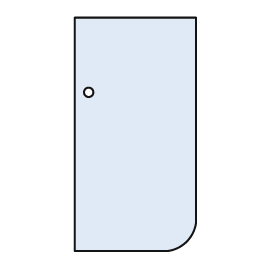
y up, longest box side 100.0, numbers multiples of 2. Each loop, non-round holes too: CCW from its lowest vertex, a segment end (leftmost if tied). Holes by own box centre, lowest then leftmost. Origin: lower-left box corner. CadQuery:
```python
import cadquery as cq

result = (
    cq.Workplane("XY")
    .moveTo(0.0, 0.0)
    .lineTo(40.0, 0.0)
    .threePointArc((48.0, 4.0), (52.0, 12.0))
    .lineTo(52.0, 100.0)
    .lineTo(0.0, 100.0)
    .close()
    .moveTo(6.0, 68.0)
    .circle(2.0)
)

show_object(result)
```